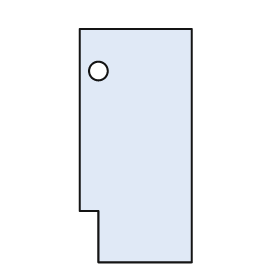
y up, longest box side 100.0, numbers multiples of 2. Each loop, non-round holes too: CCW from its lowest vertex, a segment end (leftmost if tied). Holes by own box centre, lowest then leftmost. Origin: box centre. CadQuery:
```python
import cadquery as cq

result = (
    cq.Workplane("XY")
    .moveTo(-16.0, -50.0)
    .lineTo(24.0, -50.0)
    .lineTo(24.0, 50.0)
    .lineTo(-24.0, 50.0)
    .lineTo(-24.0, -28.0)
    .lineTo(-16.0, -28.0)
    .close()
    .moveTo(-16.0, 32.0)
    .circle(4.0)
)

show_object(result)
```